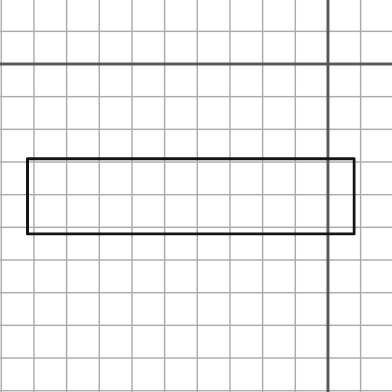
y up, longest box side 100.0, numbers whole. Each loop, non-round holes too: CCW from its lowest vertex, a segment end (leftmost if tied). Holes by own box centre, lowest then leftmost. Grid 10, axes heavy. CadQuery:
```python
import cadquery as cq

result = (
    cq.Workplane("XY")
    .moveTo(-92.0, -52.0)
    .lineTo(8.0, -52.0)
    .lineTo(8.0, -29.0)
    .lineTo(-92.0, -29.0)
    .close()
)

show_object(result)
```